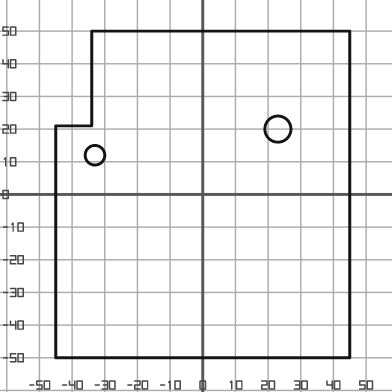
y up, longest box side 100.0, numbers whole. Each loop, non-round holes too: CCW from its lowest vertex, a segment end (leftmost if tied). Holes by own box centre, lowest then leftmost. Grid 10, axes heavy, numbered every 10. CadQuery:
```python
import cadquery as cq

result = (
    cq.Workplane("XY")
    .moveTo(-45.0, -50.0)
    .lineTo(45.0, -50.0)
    .lineTo(45.0, 50.0)
    .lineTo(-34.0, 50.0)
    .lineTo(-34.0, 21.0)
    .lineTo(-45.0, 21.0)
    .close()
    .moveTo(-33.0, 12.0)
    .circle(3.0)
    .moveTo(23.0, 20.0)
    .circle(4.0)
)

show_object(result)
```